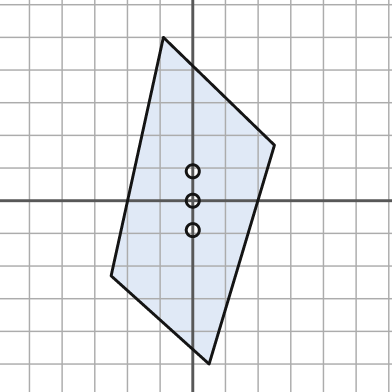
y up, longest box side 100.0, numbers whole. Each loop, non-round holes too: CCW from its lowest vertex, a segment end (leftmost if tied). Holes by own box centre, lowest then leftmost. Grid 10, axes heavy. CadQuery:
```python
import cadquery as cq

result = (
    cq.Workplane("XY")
    .moveTo(5.0, -50.0)
    .lineTo(25.0, 17.0)
    .lineTo(-9.0, 50.0)
    .lineTo(-25.0, -23.0)
    .close()
    .moveTo(0.0, -9.0)
    .circle(2.0)
    .moveTo(0.0, 0.0)
    .circle(2.0)
    .moveTo(0.0, 9.0)
    .circle(2.0)
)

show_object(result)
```